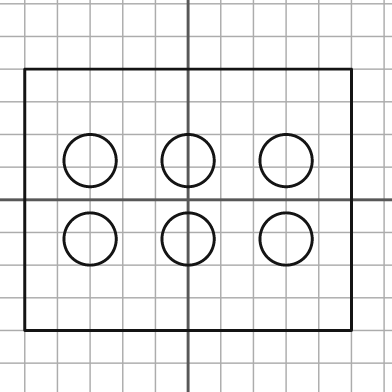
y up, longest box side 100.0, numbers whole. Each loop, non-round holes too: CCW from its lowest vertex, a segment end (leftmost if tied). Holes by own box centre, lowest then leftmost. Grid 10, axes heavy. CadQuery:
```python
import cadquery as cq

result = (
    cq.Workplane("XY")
    .moveTo(-50.0, -40.0)
    .lineTo(50.0, -40.0)
    .lineTo(50.0, 40.0)
    .lineTo(-50.0, 40.0)
    .close()
    .moveTo(-30.0, -12.0)
    .circle(8.0)
    .moveTo(0.0, -12.0)
    .circle(8.0)
    .moveTo(30.0, -12.0)
    .circle(8.0)
    .moveTo(-30.0, 12.0)
    .circle(8.0)
    .moveTo(0.0, 12.0)
    .circle(8.0)
    .moveTo(30.0, 12.0)
    .circle(8.0)
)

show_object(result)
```